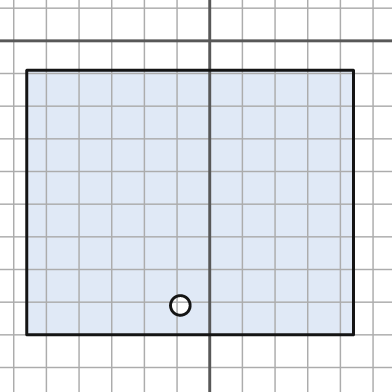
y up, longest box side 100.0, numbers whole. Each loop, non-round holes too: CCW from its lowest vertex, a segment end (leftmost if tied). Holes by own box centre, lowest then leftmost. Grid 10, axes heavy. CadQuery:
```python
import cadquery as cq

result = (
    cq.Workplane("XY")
    .moveTo(-56.0, -90.0)
    .lineTo(44.0, -90.0)
    .lineTo(44.0, -9.0)
    .lineTo(-56.0, -9.0)
    .close()
    .moveTo(-9.0, -81.0)
    .circle(3.0)
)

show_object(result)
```